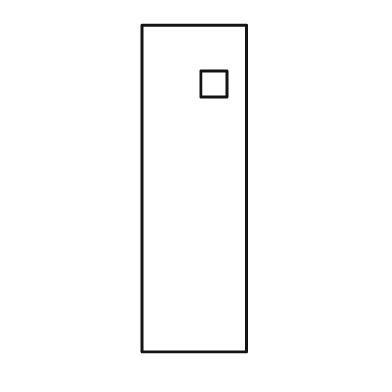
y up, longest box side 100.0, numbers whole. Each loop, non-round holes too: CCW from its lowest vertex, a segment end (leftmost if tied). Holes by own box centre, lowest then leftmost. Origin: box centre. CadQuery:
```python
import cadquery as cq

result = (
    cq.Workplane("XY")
    .moveTo(-16.0, -50.0)
    .lineTo(16.0, -50.0)
    .lineTo(16.0, 50.0)
    .lineTo(-16.0, 50.0)
    .close()
    .moveTo(2.0, 28.0)
    .lineTo(10.0, 28.0)
    .lineTo(10.0, 36.0)
    .lineTo(2.0, 36.0)
    .close()
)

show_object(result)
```